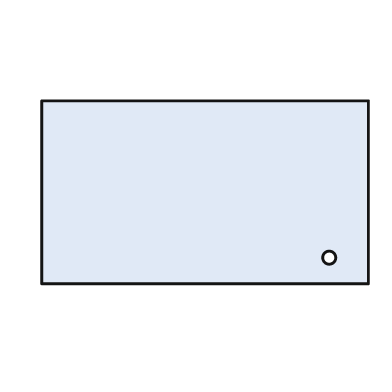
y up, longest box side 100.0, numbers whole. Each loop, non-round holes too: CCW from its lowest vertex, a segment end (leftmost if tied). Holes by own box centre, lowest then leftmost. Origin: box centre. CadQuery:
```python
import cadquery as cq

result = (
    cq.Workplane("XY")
    .moveTo(-50.0, -28.0)
    .lineTo(50.0, -28.0)
    .lineTo(50.0, 28.0)
    .lineTo(-50.0, 28.0)
    .close()
    .moveTo(38.0, -20.0)
    .circle(2.0)
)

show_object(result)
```